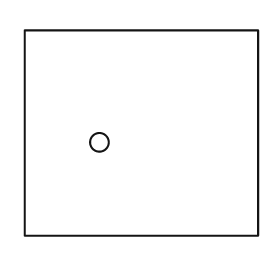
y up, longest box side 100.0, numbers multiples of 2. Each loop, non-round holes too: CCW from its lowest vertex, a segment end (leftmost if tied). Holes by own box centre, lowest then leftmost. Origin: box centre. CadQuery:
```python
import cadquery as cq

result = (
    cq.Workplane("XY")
    .moveTo(-50.0, -44.0)
    .lineTo(50.0, -44.0)
    .lineTo(50.0, 44.0)
    .lineTo(-50.0, 44.0)
    .close()
    .moveTo(-18.0, -4.0)
    .circle(4.0)
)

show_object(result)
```